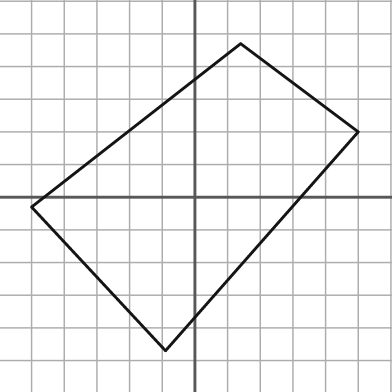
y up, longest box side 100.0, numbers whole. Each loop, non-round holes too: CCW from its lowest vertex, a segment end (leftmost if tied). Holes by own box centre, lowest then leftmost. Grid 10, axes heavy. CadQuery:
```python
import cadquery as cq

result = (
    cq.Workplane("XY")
    .moveTo(-9.0, -47.0)
    .lineTo(50.0, 20.0)
    .lineTo(14.0, 47.0)
    .lineTo(-50.0, -3.0)
    .close()
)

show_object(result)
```